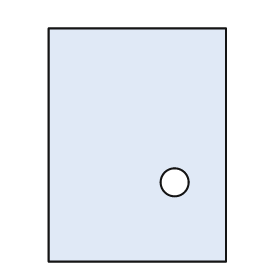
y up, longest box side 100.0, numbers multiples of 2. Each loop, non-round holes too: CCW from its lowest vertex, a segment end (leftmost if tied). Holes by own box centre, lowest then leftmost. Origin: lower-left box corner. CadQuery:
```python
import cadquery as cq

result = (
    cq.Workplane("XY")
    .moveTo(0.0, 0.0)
    .lineTo(76.0, 0.0)
    .lineTo(76.0, 100.0)
    .lineTo(0.0, 100.0)
    .close()
    .moveTo(54.0, 34.0)
    .circle(6.0)
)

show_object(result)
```